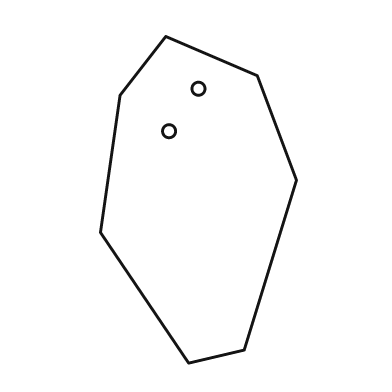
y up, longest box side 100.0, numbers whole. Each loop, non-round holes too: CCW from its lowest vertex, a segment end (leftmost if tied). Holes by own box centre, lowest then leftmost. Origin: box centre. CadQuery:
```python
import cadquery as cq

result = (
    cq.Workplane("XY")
    .moveTo(-3.0, -50.0)
    .lineTo(14.0, -46.0)
    .lineTo(30.0, 6.0)
    .lineTo(18.0, 38.0)
    .lineTo(-10.0, 50.0)
    .lineTo(-24.0, 32.0)
    .lineTo(-30.0, -10.0)
    .close()
    .moveTo(-9.0, 21.0)
    .circle(2.0)
    .moveTo(0.0, 34.0)
    .circle(2.0)
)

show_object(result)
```